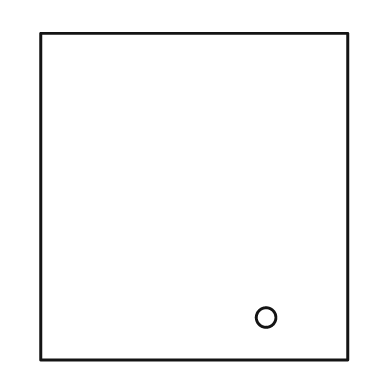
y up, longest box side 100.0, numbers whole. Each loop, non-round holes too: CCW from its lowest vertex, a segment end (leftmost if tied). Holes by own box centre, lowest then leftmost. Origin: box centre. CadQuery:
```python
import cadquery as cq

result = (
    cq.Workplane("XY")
    .moveTo(-47.0, -50.0)
    .lineTo(47.0, -50.0)
    .lineTo(47.0, 50.0)
    .lineTo(-47.0, 50.0)
    .close()
    .moveTo(22.0, -37.0)
    .circle(3.0)
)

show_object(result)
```